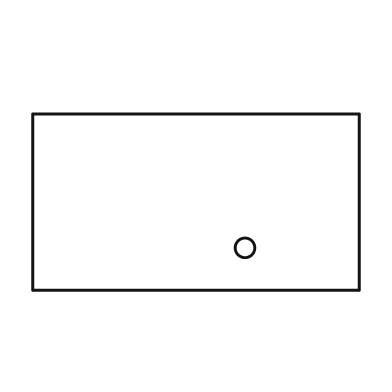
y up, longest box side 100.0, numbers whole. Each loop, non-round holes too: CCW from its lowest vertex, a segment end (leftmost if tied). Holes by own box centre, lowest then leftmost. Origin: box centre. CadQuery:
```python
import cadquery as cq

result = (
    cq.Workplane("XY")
    .moveTo(-50.0, -27.0)
    .lineTo(50.0, -27.0)
    .lineTo(50.0, 27.0)
    .lineTo(-50.0, 27.0)
    .close()
    .moveTo(15.0, -14.0)
    .circle(3.0)
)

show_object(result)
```